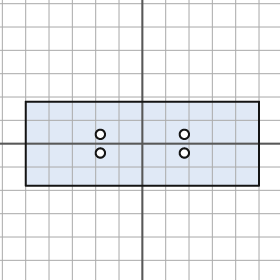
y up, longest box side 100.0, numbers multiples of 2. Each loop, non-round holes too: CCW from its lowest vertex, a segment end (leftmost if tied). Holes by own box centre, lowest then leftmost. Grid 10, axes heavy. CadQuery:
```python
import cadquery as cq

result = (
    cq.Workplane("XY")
    .moveTo(-50.0, -18.0)
    .lineTo(50.0, -18.0)
    .lineTo(50.0, 18.0)
    .lineTo(-50.0, 18.0)
    .close()
    .moveTo(-18.0, -4.0)
    .circle(2.0)
    .moveTo(18.0, -4.0)
    .circle(2.0)
    .moveTo(-18.0, 4.0)
    .circle(2.0)
    .moveTo(18.0, 4.0)
    .circle(2.0)
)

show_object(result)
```